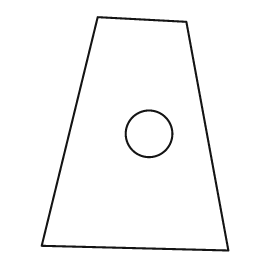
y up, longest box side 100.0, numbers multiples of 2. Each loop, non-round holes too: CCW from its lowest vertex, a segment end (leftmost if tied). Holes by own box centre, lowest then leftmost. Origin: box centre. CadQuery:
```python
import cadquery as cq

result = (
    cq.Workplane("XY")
    .moveTo(40.0, -50.0)
    .lineTo(22.0, 48.0)
    .lineTo(-16.0, 50.0)
    .lineTo(-40.0, -48.0)
    .close()
    .moveTo(6.0, 0.0)
    .circle(10.0)
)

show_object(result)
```